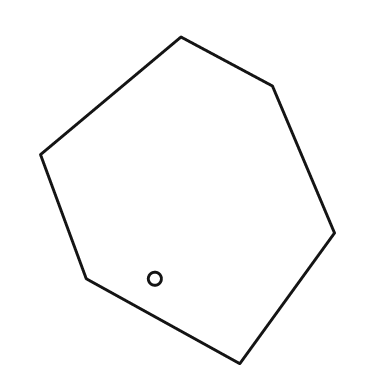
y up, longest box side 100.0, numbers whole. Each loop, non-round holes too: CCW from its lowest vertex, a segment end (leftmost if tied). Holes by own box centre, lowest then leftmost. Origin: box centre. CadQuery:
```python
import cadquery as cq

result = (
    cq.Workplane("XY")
    .moveTo(16.0, -50.0)
    .lineTo(45.0, -10.0)
    .lineTo(26.0, 35.0)
    .lineTo(-2.0, 50.0)
    .lineTo(-45.0, 14.0)
    .lineTo(-31.0, -24.0)
    .close()
    .moveTo(-10.0, -24.0)
    .circle(2.0)
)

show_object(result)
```